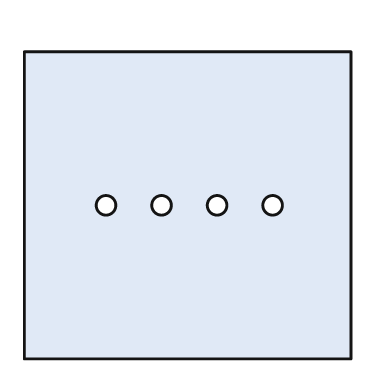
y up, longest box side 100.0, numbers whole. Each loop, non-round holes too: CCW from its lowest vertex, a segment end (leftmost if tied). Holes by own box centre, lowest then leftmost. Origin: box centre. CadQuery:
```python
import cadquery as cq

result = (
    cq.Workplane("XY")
    .moveTo(-50.0, -47.0)
    .lineTo(50.0, -47.0)
    .lineTo(50.0, 47.0)
    .lineTo(-50.0, 47.0)
    .close()
    .moveTo(-25.0, 0.0)
    .circle(3.0)
    .moveTo(-8.0, 0.0)
    .circle(3.0)
    .moveTo(9.0, 0.0)
    .circle(3.0)
    .moveTo(26.0, 0.0)
    .circle(3.0)
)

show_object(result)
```